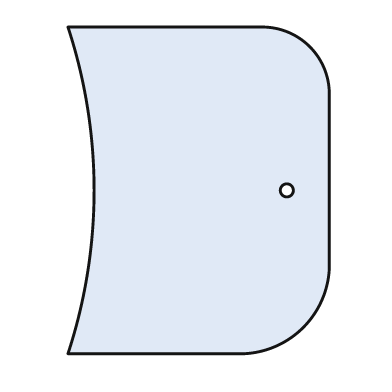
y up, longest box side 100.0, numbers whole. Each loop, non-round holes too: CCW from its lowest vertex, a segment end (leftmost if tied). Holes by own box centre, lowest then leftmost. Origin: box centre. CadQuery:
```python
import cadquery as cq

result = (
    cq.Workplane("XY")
    .moveTo(-40.0, -50.0)
    .lineTo(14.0, -50.0)
    .threePointArc((32.0, -42.0), (40.0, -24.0))
    .lineTo(40.0, 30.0)
    .threePointArc((34.0, 44.0), (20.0, 50.0))
    .lineTo(-40.0, 50.0)
    .threePointArc((-32.0, 0.0), (-40.0, -50.0))
    .close()
    .moveTo(27.0, 0.0)
    .circle(2.0)
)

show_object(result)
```